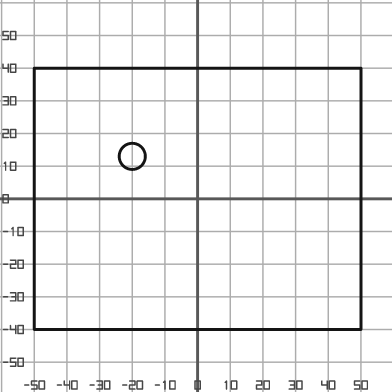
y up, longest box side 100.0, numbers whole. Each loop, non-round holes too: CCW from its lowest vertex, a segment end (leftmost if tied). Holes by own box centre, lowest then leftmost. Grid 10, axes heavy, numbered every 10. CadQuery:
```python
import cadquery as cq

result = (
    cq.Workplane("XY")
    .moveTo(-50.0, -40.0)
    .lineTo(50.0, -40.0)
    .lineTo(50.0, 40.0)
    .lineTo(-50.0, 40.0)
    .close()
    .moveTo(-20.0, 13.0)
    .circle(4.0)
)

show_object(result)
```